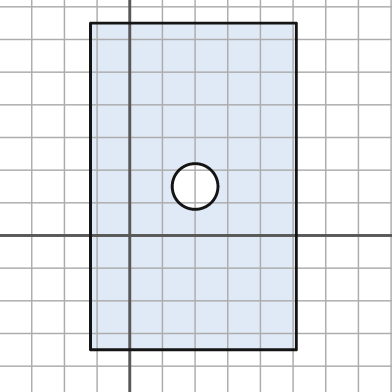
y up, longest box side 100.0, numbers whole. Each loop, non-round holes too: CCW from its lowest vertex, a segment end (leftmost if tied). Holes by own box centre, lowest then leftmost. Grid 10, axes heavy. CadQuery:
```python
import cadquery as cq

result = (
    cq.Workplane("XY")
    .moveTo(-12.0, -35.0)
    .lineTo(51.0, -35.0)
    .lineTo(51.0, 65.0)
    .lineTo(-12.0, 65.0)
    .close()
    .moveTo(20.0, 15.0)
    .circle(7.0)
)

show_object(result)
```